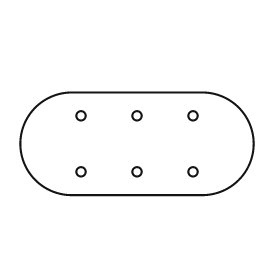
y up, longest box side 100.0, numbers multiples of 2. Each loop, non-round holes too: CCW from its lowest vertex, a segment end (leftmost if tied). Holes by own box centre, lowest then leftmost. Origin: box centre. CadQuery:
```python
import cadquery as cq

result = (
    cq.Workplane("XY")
    .moveTo(-28.0, -22.0)
    .lineTo(28.0, -22.0)
    .threePointArc((50.0, 0.0), (28.0, 22.0))
    .lineTo(-28.0, 22.0)
    .threePointArc((-50.0, 0.0), (-28.0, -22.0))
    .close()
    .moveTo(-24.0, -12.0)
    .circle(2.0)
    .moveTo(0.0, -12.0)
    .circle(2.0)
    .moveTo(24.0, -12.0)
    .circle(2.0)
    .moveTo(-24.0, 12.0)
    .circle(2.0)
    .moveTo(0.0, 12.0)
    .circle(2.0)
    .moveTo(24.0, 12.0)
    .circle(2.0)
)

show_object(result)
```